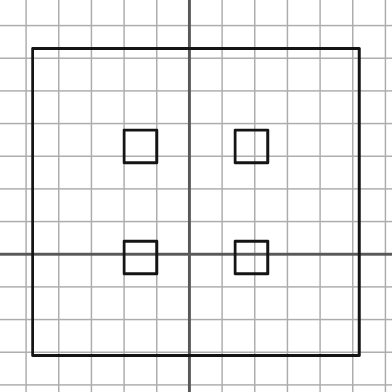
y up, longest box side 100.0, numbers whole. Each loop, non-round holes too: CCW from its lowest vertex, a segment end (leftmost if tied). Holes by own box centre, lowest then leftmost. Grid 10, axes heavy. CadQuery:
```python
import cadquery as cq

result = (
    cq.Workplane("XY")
    .moveTo(-48.0, -31.0)
    .lineTo(52.0, -31.0)
    .lineTo(52.0, 63.0)
    .lineTo(-48.0, 63.0)
    .close()
    .moveTo(-20.0, -6.0)
    .lineTo(-10.0, -6.0)
    .lineTo(-10.0, 4.0)
    .lineTo(-20.0, 4.0)
    .close()
    .moveTo(14.0, -6.0)
    .lineTo(24.0, -6.0)
    .lineTo(24.0, 4.0)
    .lineTo(14.0, 4.0)
    .close()
    .moveTo(-20.0, 28.0)
    .lineTo(-10.0, 28.0)
    .lineTo(-10.0, 38.0)
    .lineTo(-20.0, 38.0)
    .close()
    .moveTo(14.0, 28.0)
    .lineTo(24.0, 28.0)
    .lineTo(24.0, 38.0)
    .lineTo(14.0, 38.0)
    .close()
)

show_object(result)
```